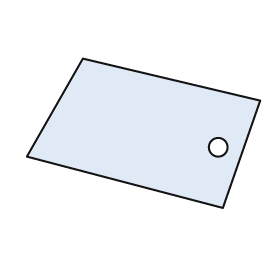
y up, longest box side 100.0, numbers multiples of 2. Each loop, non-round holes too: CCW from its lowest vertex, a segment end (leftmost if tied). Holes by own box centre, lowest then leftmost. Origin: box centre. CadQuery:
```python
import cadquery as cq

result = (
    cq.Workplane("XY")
    .moveTo(34.0, -32.0)
    .lineTo(50.0, 14.0)
    .lineTo(-26.0, 32.0)
    .lineTo(-50.0, -10.0)
    .close()
    .moveTo(32.0, -6.0)
    .circle(4.0)
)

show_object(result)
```